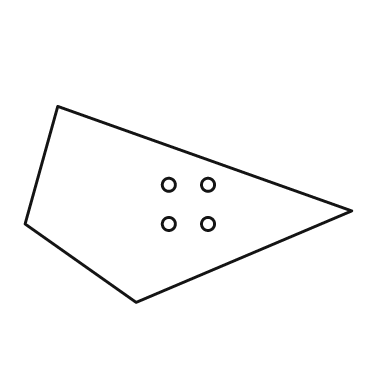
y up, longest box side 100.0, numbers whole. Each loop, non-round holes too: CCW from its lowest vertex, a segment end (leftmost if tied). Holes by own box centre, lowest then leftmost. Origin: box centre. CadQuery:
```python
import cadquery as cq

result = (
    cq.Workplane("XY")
    .moveTo(-16.0, -30.0)
    .lineTo(50.0, -2.0)
    .lineTo(-40.0, 30.0)
    .lineTo(-50.0, -6.0)
    .close()
    .moveTo(-6.0, -6.0)
    .circle(2.0)
    .moveTo(6.0, -6.0)
    .circle(2.0)
    .moveTo(-6.0, 6.0)
    .circle(2.0)
    .moveTo(6.0, 6.0)
    .circle(2.0)
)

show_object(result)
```